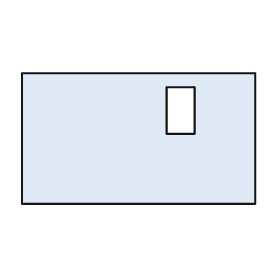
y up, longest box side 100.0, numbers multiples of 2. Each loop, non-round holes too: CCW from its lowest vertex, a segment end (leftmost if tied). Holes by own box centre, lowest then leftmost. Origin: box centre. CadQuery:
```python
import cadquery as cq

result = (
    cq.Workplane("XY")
    .moveTo(-50.0, -28.0)
    .lineTo(50.0, -28.0)
    .lineTo(50.0, 28.0)
    .lineTo(-50.0, 28.0)
    .close()
    .moveTo(12.0, 2.0)
    .lineTo(24.0, 2.0)
    .lineTo(24.0, 22.0)
    .lineTo(12.0, 22.0)
    .close()
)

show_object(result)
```